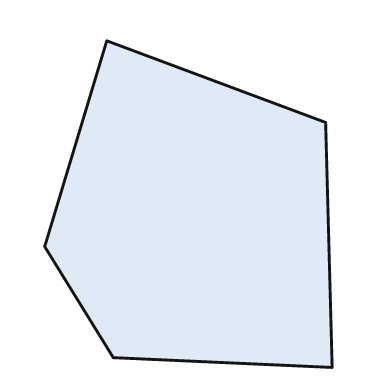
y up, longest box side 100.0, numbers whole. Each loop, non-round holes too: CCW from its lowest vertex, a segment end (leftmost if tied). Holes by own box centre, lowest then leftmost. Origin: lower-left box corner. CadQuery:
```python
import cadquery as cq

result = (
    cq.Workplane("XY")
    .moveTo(88.0, 0.0)
    .lineTo(86.0, 75.0)
    .lineTo(19.0, 100.0)
    .lineTo(0.0, 37.0)
    .lineTo(21.0, 3.0)
    .close()
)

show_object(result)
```